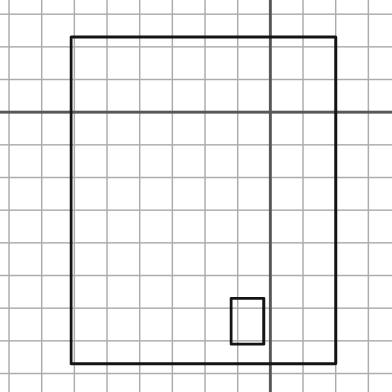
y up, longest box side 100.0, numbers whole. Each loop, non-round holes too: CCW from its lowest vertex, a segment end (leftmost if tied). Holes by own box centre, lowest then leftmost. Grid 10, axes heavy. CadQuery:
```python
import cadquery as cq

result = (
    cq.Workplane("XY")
    .moveTo(-61.0, -77.0)
    .lineTo(20.0, -77.0)
    .lineTo(20.0, 23.0)
    .lineTo(-61.0, 23.0)
    .close()
    .moveTo(-12.0, -71.0)
    .lineTo(-2.0, -71.0)
    .lineTo(-2.0, -57.0)
    .lineTo(-12.0, -57.0)
    .close()
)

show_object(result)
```